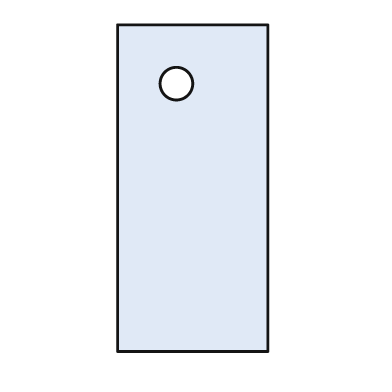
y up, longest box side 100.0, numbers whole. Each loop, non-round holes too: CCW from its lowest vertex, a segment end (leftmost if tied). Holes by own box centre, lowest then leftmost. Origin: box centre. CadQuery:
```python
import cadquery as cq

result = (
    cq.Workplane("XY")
    .moveTo(-23.0, -50.0)
    .lineTo(23.0, -50.0)
    .lineTo(23.0, 50.0)
    .lineTo(-23.0, 50.0)
    .close()
    .moveTo(-5.0, 32.0)
    .circle(5.0)
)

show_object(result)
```